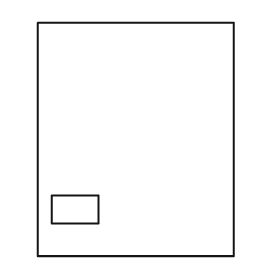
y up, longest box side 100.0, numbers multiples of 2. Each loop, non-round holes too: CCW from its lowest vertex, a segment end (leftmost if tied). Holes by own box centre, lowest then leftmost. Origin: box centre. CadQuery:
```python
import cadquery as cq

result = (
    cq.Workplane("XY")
    .moveTo(-42.0, -50.0)
    .lineTo(42.0, -50.0)
    .lineTo(42.0, 50.0)
    .lineTo(-42.0, 50.0)
    .close()
    .moveTo(-36.0, -36.0)
    .lineTo(-16.0, -36.0)
    .lineTo(-16.0, -24.0)
    .lineTo(-36.0, -24.0)
    .close()
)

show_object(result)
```